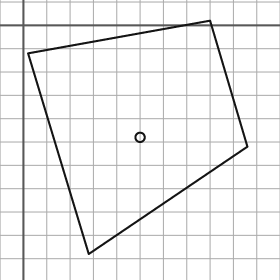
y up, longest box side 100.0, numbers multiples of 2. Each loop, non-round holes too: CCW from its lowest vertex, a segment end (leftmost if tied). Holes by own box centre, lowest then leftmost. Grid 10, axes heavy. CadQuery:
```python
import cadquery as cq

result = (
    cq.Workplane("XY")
    .moveTo(28.0, -98.0)
    .lineTo(96.0, -52.0)
    .lineTo(80.0, 2.0)
    .lineTo(2.0, -12.0)
    .close()
    .moveTo(50.0, -48.0)
    .circle(2.0)
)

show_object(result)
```